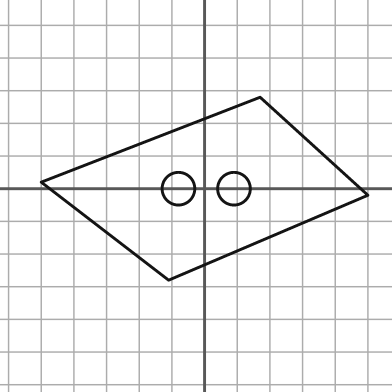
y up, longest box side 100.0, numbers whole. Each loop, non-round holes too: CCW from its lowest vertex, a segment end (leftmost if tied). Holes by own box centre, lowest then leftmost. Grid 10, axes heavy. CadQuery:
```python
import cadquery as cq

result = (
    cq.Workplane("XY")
    .moveTo(-11.0, -28.0)
    .lineTo(50.0, -2.0)
    .lineTo(17.0, 28.0)
    .lineTo(-50.0, 2.0)
    .close()
    .moveTo(-8.0, 0.0)
    .circle(5.0)
    .moveTo(9.0, 0.0)
    .circle(5.0)
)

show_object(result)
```